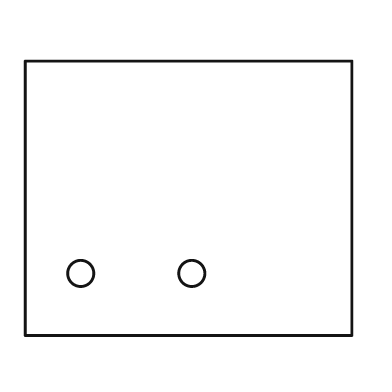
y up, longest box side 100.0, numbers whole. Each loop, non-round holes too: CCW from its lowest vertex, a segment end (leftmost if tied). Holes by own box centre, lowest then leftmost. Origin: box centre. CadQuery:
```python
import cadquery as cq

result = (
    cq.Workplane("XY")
    .moveTo(-50.0, -42.0)
    .lineTo(50.0, -42.0)
    .lineTo(50.0, 42.0)
    .lineTo(-50.0, 42.0)
    .close()
    .moveTo(-33.0, -23.0)
    .circle(4.0)
    .moveTo(1.0, -23.0)
    .circle(4.0)
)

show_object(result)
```